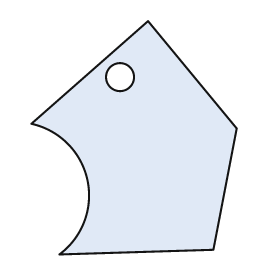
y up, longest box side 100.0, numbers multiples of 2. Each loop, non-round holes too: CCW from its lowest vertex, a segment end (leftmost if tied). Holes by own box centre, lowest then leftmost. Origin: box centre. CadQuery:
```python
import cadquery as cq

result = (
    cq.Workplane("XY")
    .moveTo(-32.0, -50.0)
    .lineTo(34.0, -48.0)
    .lineTo(44.0, 4.0)
    .lineTo(6.0, 50.0)
    .lineTo(-44.0, 6.0)
    .threePointArc((-20.0, -18.0), (-32.0, -50.0))
    .close()
    .moveTo(-6.0, 26.0)
    .circle(6.0)
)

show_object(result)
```